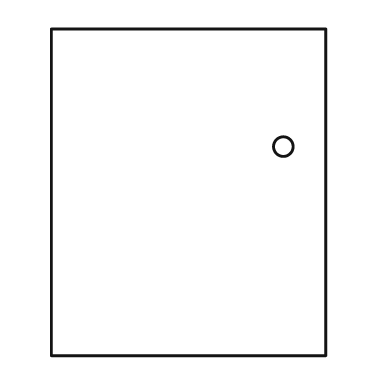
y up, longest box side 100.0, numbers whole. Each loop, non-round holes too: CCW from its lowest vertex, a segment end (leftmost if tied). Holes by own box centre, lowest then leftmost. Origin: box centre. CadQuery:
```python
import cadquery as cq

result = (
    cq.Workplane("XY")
    .moveTo(-42.0, -50.0)
    .lineTo(42.0, -50.0)
    .lineTo(42.0, 50.0)
    .lineTo(-42.0, 50.0)
    .close()
    .moveTo(29.0, 14.0)
    .circle(3.0)
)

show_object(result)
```